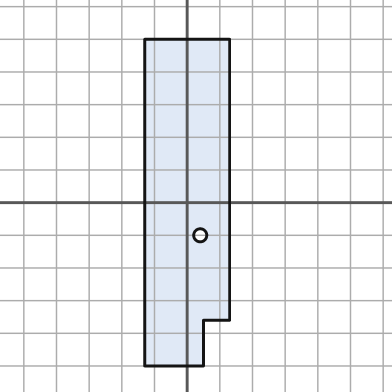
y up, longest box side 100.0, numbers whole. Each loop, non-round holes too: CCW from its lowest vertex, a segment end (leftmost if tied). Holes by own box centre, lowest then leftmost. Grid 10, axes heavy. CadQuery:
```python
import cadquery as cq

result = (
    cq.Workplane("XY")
    .moveTo(-13.0, -50.0)
    .lineTo(5.0, -50.0)
    .lineTo(5.0, -36.0)
    .lineTo(13.0, -36.0)
    .lineTo(13.0, 50.0)
    .lineTo(-13.0, 50.0)
    .close()
    .moveTo(4.0, -10.0)
    .circle(2.0)
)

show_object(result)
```